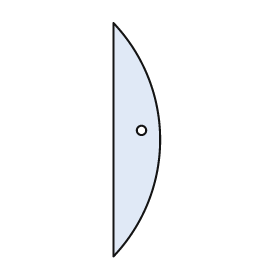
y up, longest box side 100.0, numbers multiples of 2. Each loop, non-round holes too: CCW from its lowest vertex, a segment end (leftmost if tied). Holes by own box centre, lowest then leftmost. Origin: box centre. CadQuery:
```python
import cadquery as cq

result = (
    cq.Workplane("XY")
    .moveTo(-10.0, -50.0)
    .threePointArc((10.0, 0.0), (-10.0, 50.0))
    .close()
    .moveTo(2.0, 4.0)
    .circle(2.0)
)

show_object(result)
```